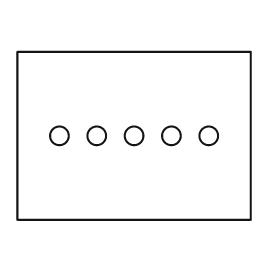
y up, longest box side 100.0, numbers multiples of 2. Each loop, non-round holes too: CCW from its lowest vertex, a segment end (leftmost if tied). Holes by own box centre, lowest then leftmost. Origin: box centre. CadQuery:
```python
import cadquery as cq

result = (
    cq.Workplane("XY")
    .moveTo(-50.0, -36.0)
    .lineTo(50.0, -36.0)
    .lineTo(50.0, 36.0)
    .lineTo(-50.0, 36.0)
    .close()
    .moveTo(-32.0, 0.0)
    .circle(4.0)
    .moveTo(-16.0, 0.0)
    .circle(4.0)
    .moveTo(0.0, 0.0)
    .circle(4.0)
    .moveTo(16.0, 0.0)
    .circle(4.0)
    .moveTo(32.0, 0.0)
    .circle(4.0)
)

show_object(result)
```